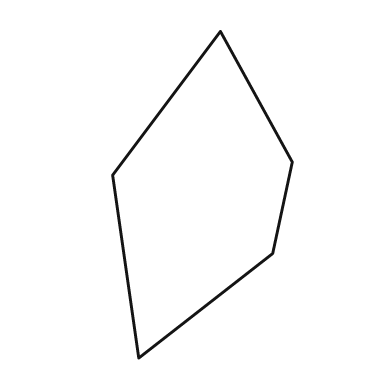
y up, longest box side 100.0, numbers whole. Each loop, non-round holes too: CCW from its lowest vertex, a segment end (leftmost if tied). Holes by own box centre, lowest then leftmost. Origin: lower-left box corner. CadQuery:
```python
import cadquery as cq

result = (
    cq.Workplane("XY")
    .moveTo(8.0, 0.0)
    .lineTo(49.0, 32.0)
    .lineTo(55.0, 60.0)
    .lineTo(33.0, 100.0)
    .lineTo(0.0, 56.0)
    .close()
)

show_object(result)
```